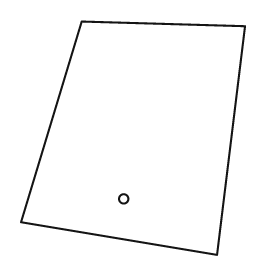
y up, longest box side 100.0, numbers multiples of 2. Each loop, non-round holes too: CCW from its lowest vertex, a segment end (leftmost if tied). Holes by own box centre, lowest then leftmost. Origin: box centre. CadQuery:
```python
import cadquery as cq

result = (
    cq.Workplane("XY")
    .moveTo(36.0, -50.0)
    .lineTo(48.0, 48.0)
    .lineTo(-22.0, 50.0)
    .lineTo(-48.0, -36.0)
    .close()
    .moveTo(-4.0, -26.0)
    .circle(2.0)
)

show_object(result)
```